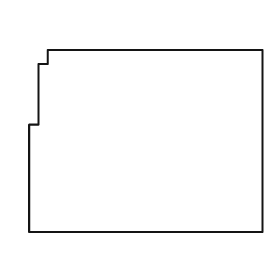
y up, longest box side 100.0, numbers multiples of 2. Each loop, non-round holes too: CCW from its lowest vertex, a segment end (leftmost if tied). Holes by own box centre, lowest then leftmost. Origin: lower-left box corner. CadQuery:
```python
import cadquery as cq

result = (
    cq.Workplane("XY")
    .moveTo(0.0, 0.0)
    .lineTo(100.0, 0.0)
    .lineTo(100.0, 78.0)
    .lineTo(8.0, 78.0)
    .lineTo(8.0, 72.0)
    .lineTo(4.0, 72.0)
    .lineTo(4.0, 46.0)
    .lineTo(0.0, 46.0)
    .close()
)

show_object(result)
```